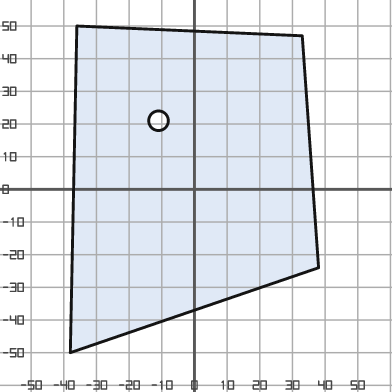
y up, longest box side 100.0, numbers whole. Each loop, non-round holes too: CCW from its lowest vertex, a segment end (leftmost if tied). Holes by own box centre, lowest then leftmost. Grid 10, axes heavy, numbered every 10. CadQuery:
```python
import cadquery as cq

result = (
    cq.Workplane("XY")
    .moveTo(-38.0, -50.0)
    .lineTo(38.0, -24.0)
    .lineTo(33.0, 47.0)
    .lineTo(-36.0, 50.0)
    .close()
    .moveTo(-11.0, 21.0)
    .circle(3.0)
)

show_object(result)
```